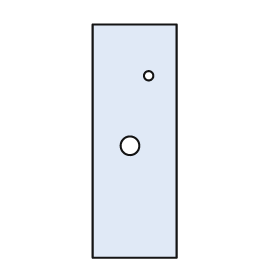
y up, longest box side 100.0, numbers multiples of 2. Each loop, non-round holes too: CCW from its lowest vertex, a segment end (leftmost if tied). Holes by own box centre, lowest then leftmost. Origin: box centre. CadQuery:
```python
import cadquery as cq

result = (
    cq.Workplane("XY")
    .moveTo(-18.0, -50.0)
    .lineTo(18.0, -50.0)
    .lineTo(18.0, 50.0)
    .lineTo(-18.0, 50.0)
    .close()
    .moveTo(-2.0, -2.0)
    .circle(4.0)
    .moveTo(6.0, 28.0)
    .circle(2.0)
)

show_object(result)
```